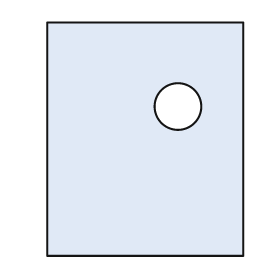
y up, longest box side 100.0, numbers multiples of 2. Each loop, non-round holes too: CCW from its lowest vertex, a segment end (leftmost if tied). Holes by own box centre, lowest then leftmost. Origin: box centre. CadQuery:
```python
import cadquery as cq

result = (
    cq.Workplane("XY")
    .moveTo(-42.0, -50.0)
    .lineTo(42.0, -50.0)
    .lineTo(42.0, 50.0)
    .lineTo(-42.0, 50.0)
    .close()
    .moveTo(14.0, 14.0)
    .circle(10.0)
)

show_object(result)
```